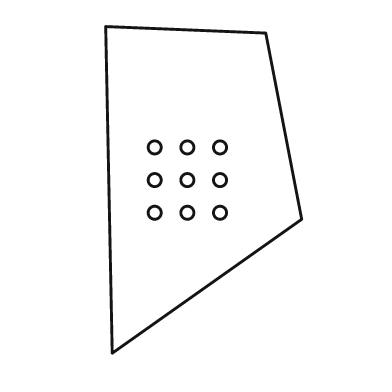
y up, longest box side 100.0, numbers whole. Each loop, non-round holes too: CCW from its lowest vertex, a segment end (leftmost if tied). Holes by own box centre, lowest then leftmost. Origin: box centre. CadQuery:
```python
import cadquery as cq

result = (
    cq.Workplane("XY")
    .moveTo(-28.0, -50.0)
    .lineTo(30.0, -9.0)
    .lineTo(19.0, 48.0)
    .lineTo(-30.0, 50.0)
    .close()
    .moveTo(-15.0, -7.0)
    .circle(2.0)
    .moveTo(-5.0, -7.0)
    .circle(2.0)
    .moveTo(5.0, -7.0)
    .circle(2.0)
    .moveTo(-15.0, 3.0)
    .circle(2.0)
    .moveTo(-5.0, 3.0)
    .circle(2.0)
    .moveTo(5.0, 3.0)
    .circle(2.0)
    .moveTo(-15.0, 13.0)
    .circle(2.0)
    .moveTo(-5.0, 13.0)
    .circle(2.0)
    .moveTo(5.0, 13.0)
    .circle(2.0)
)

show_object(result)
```